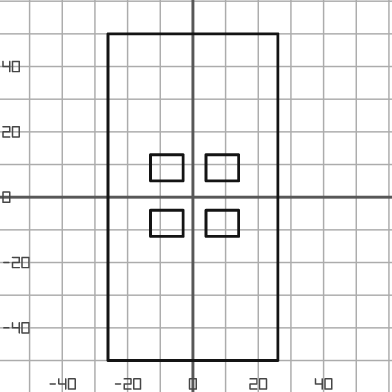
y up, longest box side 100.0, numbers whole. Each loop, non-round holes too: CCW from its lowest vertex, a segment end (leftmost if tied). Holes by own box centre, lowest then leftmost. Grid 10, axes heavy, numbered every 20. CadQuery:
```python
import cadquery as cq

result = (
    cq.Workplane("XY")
    .moveTo(-26.0, -50.0)
    .lineTo(26.0, -50.0)
    .lineTo(26.0, 50.0)
    .lineTo(-26.0, 50.0)
    .close()
    .moveTo(-13.0, -12.0)
    .lineTo(-3.0, -12.0)
    .lineTo(-3.0, -4.0)
    .lineTo(-13.0, -4.0)
    .close()
    .moveTo(4.0, -12.0)
    .lineTo(14.0, -12.0)
    .lineTo(14.0, -4.0)
    .lineTo(4.0, -4.0)
    .close()
    .moveTo(-13.0, 5.0)
    .lineTo(-3.0, 5.0)
    .lineTo(-3.0, 13.0)
    .lineTo(-13.0, 13.0)
    .close()
    .moveTo(4.0, 5.0)
    .lineTo(14.0, 5.0)
    .lineTo(14.0, 13.0)
    .lineTo(4.0, 13.0)
    .close()
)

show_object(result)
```